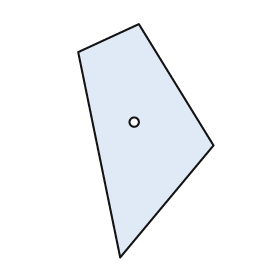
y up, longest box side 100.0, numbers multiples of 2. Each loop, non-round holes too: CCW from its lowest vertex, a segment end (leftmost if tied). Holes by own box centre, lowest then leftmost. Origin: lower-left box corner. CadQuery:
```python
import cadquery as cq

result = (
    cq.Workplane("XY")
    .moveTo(18.0, 0.0)
    .lineTo(58.0, 48.0)
    .lineTo(26.0, 100.0)
    .lineTo(0.0, 88.0)
    .close()
    .moveTo(24.0, 58.0)
    .circle(2.0)
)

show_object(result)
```